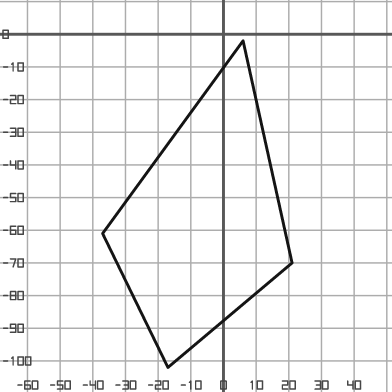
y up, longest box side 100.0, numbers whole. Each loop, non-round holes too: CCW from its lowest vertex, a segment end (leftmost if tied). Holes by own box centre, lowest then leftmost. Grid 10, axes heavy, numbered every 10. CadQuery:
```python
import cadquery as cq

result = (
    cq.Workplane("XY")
    .moveTo(-17.0, -102.0)
    .lineTo(21.0, -70.0)
    .lineTo(6.0, -2.0)
    .lineTo(-37.0, -61.0)
    .close()
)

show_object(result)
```